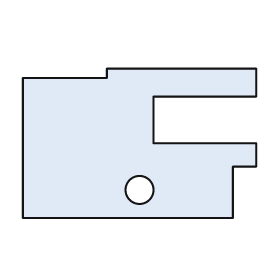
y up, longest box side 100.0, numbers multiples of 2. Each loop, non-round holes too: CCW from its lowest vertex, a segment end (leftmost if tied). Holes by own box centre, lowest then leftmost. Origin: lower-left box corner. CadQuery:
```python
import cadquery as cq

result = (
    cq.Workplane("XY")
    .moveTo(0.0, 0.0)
    .lineTo(90.0, 0.0)
    .lineTo(90.0, 22.0)
    .lineTo(100.0, 22.0)
    .lineTo(100.0, 32.0)
    .lineTo(56.0, 32.0)
    .lineTo(56.0, 52.0)
    .lineTo(100.0, 52.0)
    .lineTo(100.0, 64.0)
    .lineTo(36.0, 64.0)
    .lineTo(36.0, 60.0)
    .lineTo(0.0, 60.0)
    .close()
    .moveTo(50.0, 12.0)
    .circle(6.0)
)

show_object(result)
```